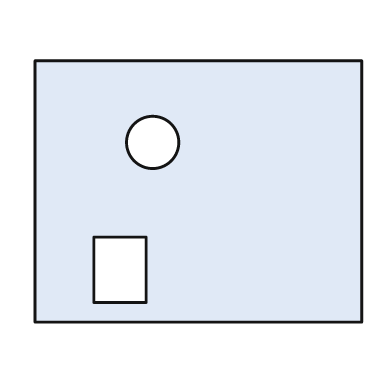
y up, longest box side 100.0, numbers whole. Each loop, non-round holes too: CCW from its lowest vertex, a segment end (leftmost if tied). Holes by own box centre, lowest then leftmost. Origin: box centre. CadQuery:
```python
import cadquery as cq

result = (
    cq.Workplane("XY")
    .moveTo(-50.0, -40.0)
    .lineTo(50.0, -40.0)
    .lineTo(50.0, 40.0)
    .lineTo(-50.0, 40.0)
    .close()
    .moveTo(-32.0, -34.0)
    .lineTo(-16.0, -34.0)
    .lineTo(-16.0, -14.0)
    .lineTo(-32.0, -14.0)
    .close()
    .moveTo(-14.0, 15.0)
    .circle(8.0)
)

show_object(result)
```